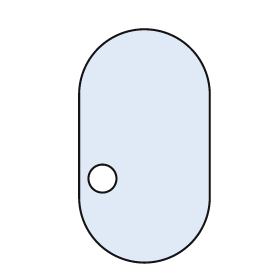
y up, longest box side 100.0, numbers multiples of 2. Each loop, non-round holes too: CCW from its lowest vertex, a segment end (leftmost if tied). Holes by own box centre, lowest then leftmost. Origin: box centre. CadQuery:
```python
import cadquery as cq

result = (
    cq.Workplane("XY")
    .moveTo(-28.0, -22.0)
    .threePointArc((0.0, -50.0), (28.0, -22.0))
    .lineTo(28.0, 22.0)
    .threePointArc((0.0, 50.0), (-28.0, 22.0))
    .close()
    .moveTo(-18.0, -14.0)
    .circle(6.0)
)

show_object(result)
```